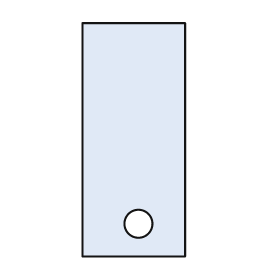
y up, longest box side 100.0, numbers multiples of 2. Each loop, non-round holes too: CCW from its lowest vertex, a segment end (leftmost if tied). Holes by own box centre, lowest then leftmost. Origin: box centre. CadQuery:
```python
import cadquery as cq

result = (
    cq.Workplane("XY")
    .moveTo(-22.0, -50.0)
    .lineTo(22.0, -50.0)
    .lineTo(22.0, 50.0)
    .lineTo(-22.0, 50.0)
    .close()
    .moveTo(2.0, -36.0)
    .circle(6.0)
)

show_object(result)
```